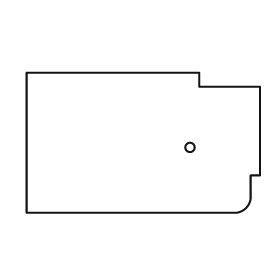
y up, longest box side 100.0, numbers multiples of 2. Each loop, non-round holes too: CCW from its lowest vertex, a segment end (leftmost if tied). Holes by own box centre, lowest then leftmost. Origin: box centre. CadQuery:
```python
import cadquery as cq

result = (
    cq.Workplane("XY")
    .moveTo(-50.0, -30.0)
    .lineTo(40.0, -30.0)
    .threePointArc((44.0, -28.0), (46.0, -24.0))
    .lineTo(46.0, -14.0)
    .lineTo(50.0, -14.0)
    .lineTo(50.0, 24.0)
    .lineTo(24.0, 24.0)
    .lineTo(24.0, 30.0)
    .lineTo(-50.0, 30.0)
    .close()
    .moveTo(20.0, -2.0)
    .circle(2.0)
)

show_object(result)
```